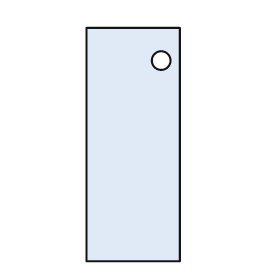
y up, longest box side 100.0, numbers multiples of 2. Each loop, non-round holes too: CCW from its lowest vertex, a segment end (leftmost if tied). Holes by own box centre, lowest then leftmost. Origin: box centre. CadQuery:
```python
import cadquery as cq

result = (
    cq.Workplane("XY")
    .moveTo(-20.0, -50.0)
    .lineTo(20.0, -50.0)
    .lineTo(20.0, 50.0)
    .lineTo(-20.0, 50.0)
    .close()
    .moveTo(12.0, 36.0)
    .circle(4.0)
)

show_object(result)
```